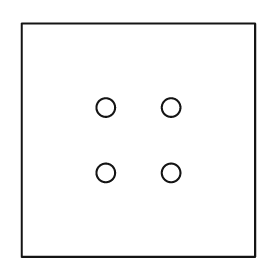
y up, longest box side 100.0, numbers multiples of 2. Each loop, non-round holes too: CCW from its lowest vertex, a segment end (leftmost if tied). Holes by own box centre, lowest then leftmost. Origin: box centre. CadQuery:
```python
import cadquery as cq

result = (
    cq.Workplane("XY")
    .moveTo(-50.0, -50.0)
    .lineTo(50.0, -50.0)
    .lineTo(50.0, 50.0)
    .lineTo(-50.0, 50.0)
    .close()
    .moveTo(-14.0, -14.0)
    .circle(4.0)
    .moveTo(14.0, -14.0)
    .circle(4.0)
    .moveTo(-14.0, 14.0)
    .circle(4.0)
    .moveTo(14.0, 14.0)
    .circle(4.0)
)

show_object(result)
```